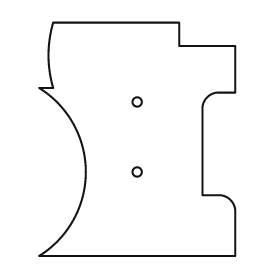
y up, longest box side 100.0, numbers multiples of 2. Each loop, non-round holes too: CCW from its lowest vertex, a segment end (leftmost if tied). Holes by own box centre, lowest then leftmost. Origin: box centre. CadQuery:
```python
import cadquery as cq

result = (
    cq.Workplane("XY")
    .moveTo(-42.0, -50.0)
    .lineTo(42.0, -50.0)
    .lineTo(42.0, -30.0)
    .threePointArc((40.0, -26.0), (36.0, -24.0))
    .lineTo(28.0, -24.0)
    .lineTo(28.0, 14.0)
    .threePointArc((30.0, 18.0), (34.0, 20.0))
    .lineTo(42.0, 20.0)
    .lineTo(42.0, 40.0)
    .lineTo(18.0, 40.0)
    .lineTo(18.0, 50.0)
    .lineTo(-36.0, 50.0)
    .threePointArc((-38.0, 36.0), (-36.0, 22.0))
    .lineTo(-42.0, 22.0)
    .threePointArc((-22.0, -14.0), (-42.0, -50.0))
    .close()
    .moveTo(0.0, -14.0)
    .circle(2.0)
    .moveTo(0.0, 16.0)
    .circle(2.0)
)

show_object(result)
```